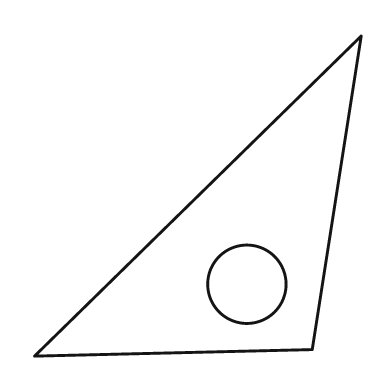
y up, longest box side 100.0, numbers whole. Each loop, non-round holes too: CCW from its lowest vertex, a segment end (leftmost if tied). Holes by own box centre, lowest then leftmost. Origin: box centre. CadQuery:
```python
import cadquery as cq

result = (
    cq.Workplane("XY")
    .moveTo(-50.0, -49.0)
    .lineTo(35.0, -47.0)
    .lineTo(50.0, 49.0)
    .close()
    .moveTo(15.0, -27.0)
    .circle(12.0)
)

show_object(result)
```